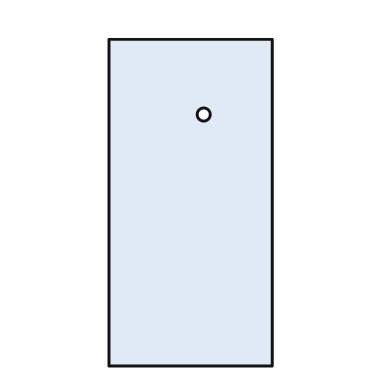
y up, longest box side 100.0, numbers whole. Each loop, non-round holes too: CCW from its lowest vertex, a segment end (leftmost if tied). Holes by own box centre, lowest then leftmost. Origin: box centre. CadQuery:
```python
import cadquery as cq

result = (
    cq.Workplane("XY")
    .moveTo(-25.0, -50.0)
    .lineTo(25.0, -50.0)
    .lineTo(25.0, 50.0)
    .lineTo(-25.0, 50.0)
    .close()
    .moveTo(4.0, 27.0)
    .circle(2.0)
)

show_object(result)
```